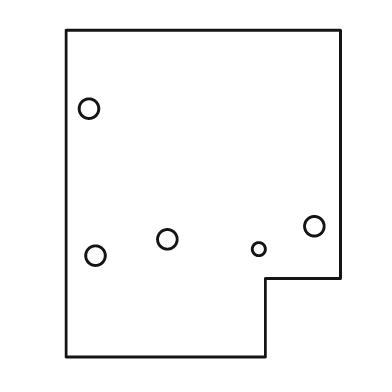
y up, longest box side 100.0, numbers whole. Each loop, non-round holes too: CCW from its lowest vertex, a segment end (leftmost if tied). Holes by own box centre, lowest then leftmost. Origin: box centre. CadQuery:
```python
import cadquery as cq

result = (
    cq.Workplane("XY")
    .moveTo(-42.0, -50.0)
    .lineTo(19.0, -50.0)
    .lineTo(19.0, -26.0)
    .lineTo(42.0, -26.0)
    .lineTo(42.0, 50.0)
    .lineTo(-42.0, 50.0)
    .close()
    .moveTo(-33.0, -19.0)
    .circle(3.0)
    .moveTo(17.0, -17.0)
    .circle(2.0)
    .moveTo(-11.0, -14.0)
    .circle(3.0)
    .moveTo(34.0, -10.0)
    .circle(3.0)
    .moveTo(-35.0, 26.0)
    .circle(3.0)
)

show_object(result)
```